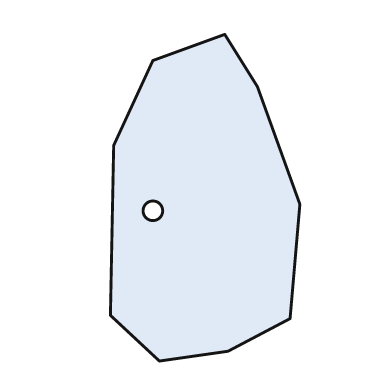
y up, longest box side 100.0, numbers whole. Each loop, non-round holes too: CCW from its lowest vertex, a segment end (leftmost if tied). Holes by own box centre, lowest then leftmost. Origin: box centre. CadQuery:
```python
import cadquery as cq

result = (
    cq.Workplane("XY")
    .moveTo(-14.0, -50.0)
    .lineTo(7.0, -47.0)
    .lineTo(26.0, -37.0)
    .lineTo(29.0, -2.0)
    .lineTo(16.0, 34.0)
    .lineTo(6.0, 50.0)
    .lineTo(-16.0, 42.0)
    .lineTo(-28.0, 16.0)
    .lineTo(-29.0, -36.0)
    .close()
    .moveTo(-16.0, -4.0)
    .circle(3.0)
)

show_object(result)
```